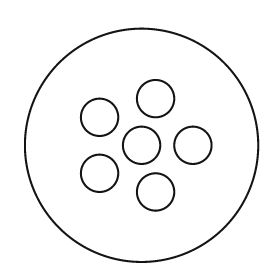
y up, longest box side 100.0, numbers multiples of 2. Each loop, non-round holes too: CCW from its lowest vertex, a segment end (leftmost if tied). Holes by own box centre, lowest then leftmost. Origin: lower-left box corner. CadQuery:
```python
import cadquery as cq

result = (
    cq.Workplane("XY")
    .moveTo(50.0, 50.0)
    .circle(50.0)
    .moveTo(56.0, 30.0)
    .circle(8.0)
    .moveTo(32.0, 38.0)
    .circle(8.0)
    .moveTo(50.0, 50.0)
    .circle(8.0)
    .moveTo(72.0, 50.0)
    .circle(8.0)
    .moveTo(32.0, 62.0)
    .circle(8.0)
    .moveTo(56.0, 70.0)
    .circle(8.0)
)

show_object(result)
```